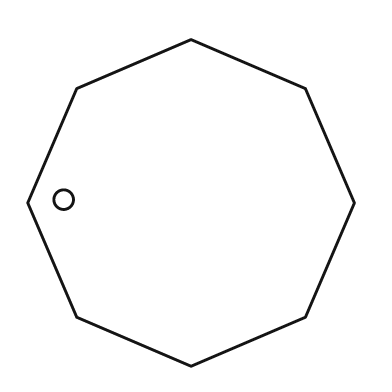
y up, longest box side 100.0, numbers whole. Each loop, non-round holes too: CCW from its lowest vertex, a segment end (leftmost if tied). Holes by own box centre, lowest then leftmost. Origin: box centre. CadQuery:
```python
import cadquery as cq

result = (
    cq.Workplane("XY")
    .moveTo(0.0, -50.0)
    .lineTo(35.0, -35.0)
    .lineTo(50.0, 0.0)
    .lineTo(35.0, 35.0)
    .lineTo(0.0, 50.0)
    .lineTo(-35.0, 35.0)
    .lineTo(-50.0, 0.0)
    .lineTo(-35.0, -35.0)
    .close()
    .moveTo(-39.0, 1.0)
    .circle(3.0)
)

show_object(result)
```